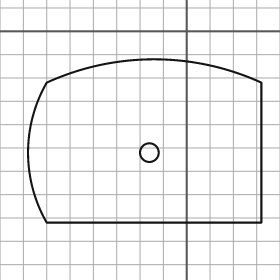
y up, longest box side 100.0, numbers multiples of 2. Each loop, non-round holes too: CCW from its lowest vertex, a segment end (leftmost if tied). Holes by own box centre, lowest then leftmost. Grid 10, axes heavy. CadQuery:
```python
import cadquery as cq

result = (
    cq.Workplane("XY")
    .moveTo(-60.0, -82.0)
    .lineTo(32.0, -82.0)
    .lineTo(32.0, -22.0)
    .threePointArc((-14.0, -12.0), (-60.0, -22.0))
    .threePointArc((-68.0, -52.0), (-60.0, -82.0))
    .close()
    .moveTo(-16.0, -52.0)
    .circle(4.0)
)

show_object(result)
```